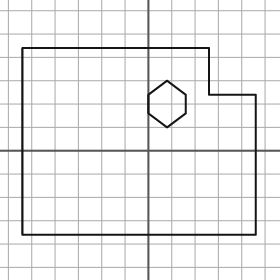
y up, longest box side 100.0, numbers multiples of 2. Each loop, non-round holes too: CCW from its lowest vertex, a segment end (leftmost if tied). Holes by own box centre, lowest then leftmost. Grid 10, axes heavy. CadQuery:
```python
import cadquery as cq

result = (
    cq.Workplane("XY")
    .moveTo(-54.0, -36.0)
    .lineTo(46.0, -36.0)
    .lineTo(46.0, 24.0)
    .lineTo(26.0, 24.0)
    .lineTo(26.0, 44.0)
    .lineTo(-54.0, 44.0)
    .close()
    .moveTo(8.0, 10.0)
    .lineTo(16.0, 16.0)
    .lineTo(16.0, 24.0)
    .lineTo(8.0, 30.0)
    .lineTo(0.0, 24.0)
    .lineTo(0.0, 16.0)
    .close()
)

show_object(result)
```